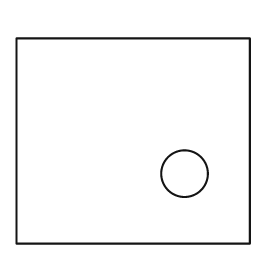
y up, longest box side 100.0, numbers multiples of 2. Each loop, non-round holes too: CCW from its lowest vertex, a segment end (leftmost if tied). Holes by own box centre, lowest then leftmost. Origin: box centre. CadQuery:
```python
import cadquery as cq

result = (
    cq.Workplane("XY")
    .moveTo(-50.0, -44.0)
    .lineTo(50.0, -44.0)
    .lineTo(50.0, 44.0)
    .lineTo(-50.0, 44.0)
    .close()
    .moveTo(22.0, -14.0)
    .circle(10.0)
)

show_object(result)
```